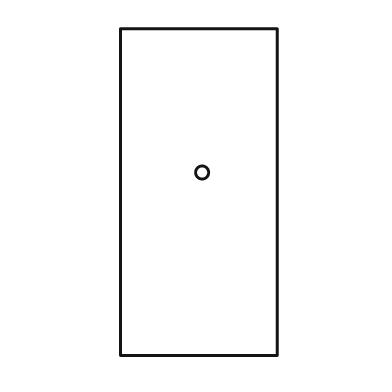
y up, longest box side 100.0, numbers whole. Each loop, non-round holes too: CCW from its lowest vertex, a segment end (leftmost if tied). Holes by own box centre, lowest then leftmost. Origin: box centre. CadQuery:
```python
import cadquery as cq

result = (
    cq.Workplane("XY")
    .moveTo(-24.0, -50.0)
    .lineTo(24.0, -50.0)
    .lineTo(24.0, 50.0)
    .lineTo(-24.0, 50.0)
    .close()
    .moveTo(1.0, 6.0)
    .circle(2.0)
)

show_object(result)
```